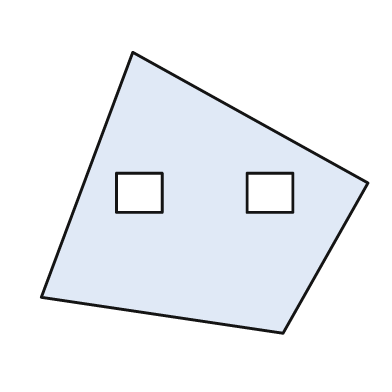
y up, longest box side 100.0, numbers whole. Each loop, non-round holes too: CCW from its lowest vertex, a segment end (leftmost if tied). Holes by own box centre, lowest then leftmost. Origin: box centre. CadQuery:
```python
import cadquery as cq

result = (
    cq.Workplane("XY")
    .moveTo(24.0, -43.0)
    .lineTo(50.0, 3.0)
    .lineTo(-22.0, 43.0)
    .lineTo(-50.0, -32.0)
    .close()
    .moveTo(-27.0, -6.0)
    .lineTo(-13.0, -6.0)
    .lineTo(-13.0, 6.0)
    .lineTo(-27.0, 6.0)
    .close()
    .moveTo(13.0, -6.0)
    .lineTo(27.0, -6.0)
    .lineTo(27.0, 6.0)
    .lineTo(13.0, 6.0)
    .close()
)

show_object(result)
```